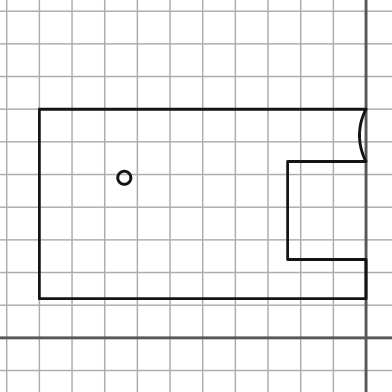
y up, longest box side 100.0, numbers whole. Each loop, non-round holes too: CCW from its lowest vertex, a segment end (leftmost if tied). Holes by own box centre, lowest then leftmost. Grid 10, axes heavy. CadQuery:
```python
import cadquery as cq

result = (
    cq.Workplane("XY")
    .moveTo(-100.0, 12.0)
    .lineTo(0.0, 12.0)
    .lineTo(0.0, 24.0)
    .lineTo(-24.0, 24.0)
    .lineTo(-24.0, 54.0)
    .lineTo(0.0, 54.0)
    .threePointArc((-2.0, 62.0), (0.0, 70.0))
    .lineTo(-100.0, 70.0)
    .close()
    .moveTo(-74.0, 49.0)
    .circle(2.0)
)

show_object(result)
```